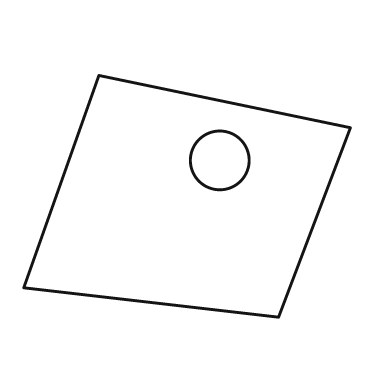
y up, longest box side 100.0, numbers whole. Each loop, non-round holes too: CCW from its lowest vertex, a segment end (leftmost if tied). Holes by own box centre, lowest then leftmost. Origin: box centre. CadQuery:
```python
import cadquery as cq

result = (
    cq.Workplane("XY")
    .moveTo(28.0, -37.0)
    .lineTo(50.0, 21.0)
    .lineTo(-27.0, 37.0)
    .lineTo(-50.0, -28.0)
    .close()
    .moveTo(10.0, 11.0)
    .circle(9.0)
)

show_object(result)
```